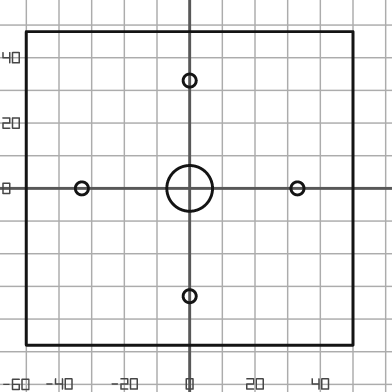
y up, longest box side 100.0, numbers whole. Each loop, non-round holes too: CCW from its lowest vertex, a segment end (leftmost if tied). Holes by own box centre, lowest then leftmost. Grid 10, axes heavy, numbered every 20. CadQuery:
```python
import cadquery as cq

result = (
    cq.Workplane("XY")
    .moveTo(-50.0, -48.0)
    .lineTo(50.0, -48.0)
    .lineTo(50.0, 48.0)
    .lineTo(-50.0, 48.0)
    .close()
    .moveTo(0.0, -33.0)
    .circle(2.0)
    .moveTo(-33.0, 0.0)
    .circle(2.0)
    .moveTo(0.0, 0.0)
    .circle(7.0)
    .moveTo(33.0, 0.0)
    .circle(2.0)
    .moveTo(0.0, 33.0)
    .circle(2.0)
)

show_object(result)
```